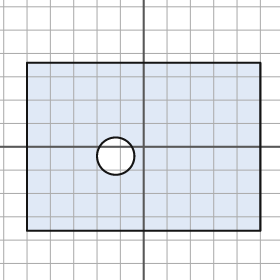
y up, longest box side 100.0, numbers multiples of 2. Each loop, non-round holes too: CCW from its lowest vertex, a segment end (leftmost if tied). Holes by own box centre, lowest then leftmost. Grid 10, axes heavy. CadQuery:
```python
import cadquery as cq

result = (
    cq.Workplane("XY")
    .moveTo(-50.0, -36.0)
    .lineTo(50.0, -36.0)
    .lineTo(50.0, 36.0)
    .lineTo(-50.0, 36.0)
    .close()
    .moveTo(-12.0, -4.0)
    .circle(8.0)
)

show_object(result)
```